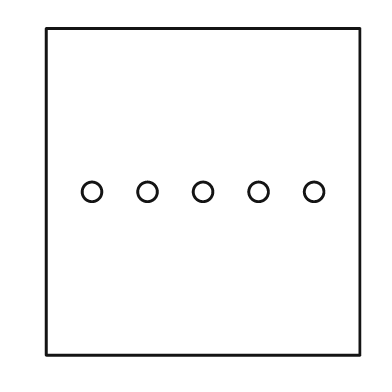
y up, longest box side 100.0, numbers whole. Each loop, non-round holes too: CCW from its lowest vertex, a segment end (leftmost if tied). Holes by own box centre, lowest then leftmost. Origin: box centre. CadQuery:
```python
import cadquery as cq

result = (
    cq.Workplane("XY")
    .moveTo(-48.0, -50.0)
    .lineTo(48.0, -50.0)
    .lineTo(48.0, 50.0)
    .lineTo(-48.0, 50.0)
    .close()
    .moveTo(-34.0, 0.0)
    .circle(3.0)
    .moveTo(-17.0, 0.0)
    .circle(3.0)
    .moveTo(0.0, 0.0)
    .circle(3.0)
    .moveTo(17.0, 0.0)
    .circle(3.0)
    .moveTo(34.0, 0.0)
    .circle(3.0)
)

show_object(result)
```